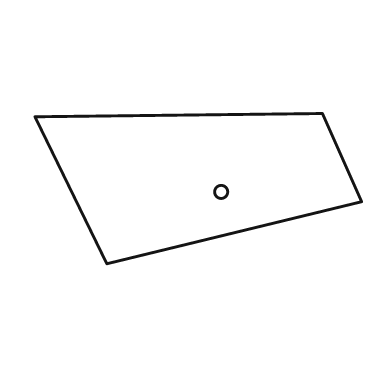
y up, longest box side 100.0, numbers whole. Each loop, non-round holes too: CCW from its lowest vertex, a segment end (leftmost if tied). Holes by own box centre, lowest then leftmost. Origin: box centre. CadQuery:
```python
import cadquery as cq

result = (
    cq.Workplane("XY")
    .moveTo(-28.0, -23.0)
    .lineTo(50.0, -4.0)
    .lineTo(38.0, 23.0)
    .lineTo(-50.0, 22.0)
    .close()
    .moveTo(7.0, -1.0)
    .circle(2.0)
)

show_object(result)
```